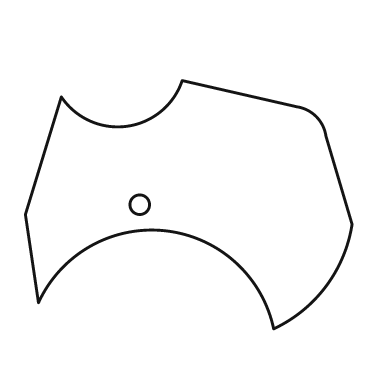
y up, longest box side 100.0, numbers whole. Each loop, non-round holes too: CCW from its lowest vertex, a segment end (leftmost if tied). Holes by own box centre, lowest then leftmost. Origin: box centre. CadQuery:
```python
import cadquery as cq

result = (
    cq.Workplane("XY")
    .moveTo(26.0, -38.0)
    .threePointArc((42.0, -25.0), (50.0, -6.0))
    .lineTo(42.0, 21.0)
    .threePointArc((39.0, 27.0), (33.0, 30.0))
    .lineTo(-2.0, 38.0)
    .threePointArc((-19.0, 24.0), (-39.0, 33.0))
    .lineTo(-50.0, -3.0)
    .lineTo(-46.0, -30.0)
    .threePointArc((-7.0, -8.0), (26.0, -38.0))
    .close()
    .moveTo(-15.0, 0.0)
    .circle(3.0)
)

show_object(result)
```